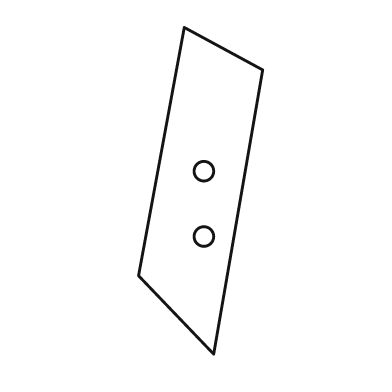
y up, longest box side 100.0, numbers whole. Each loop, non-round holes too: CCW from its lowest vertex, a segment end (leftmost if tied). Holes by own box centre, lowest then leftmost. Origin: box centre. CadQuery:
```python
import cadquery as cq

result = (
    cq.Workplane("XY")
    .moveTo(4.0, -50.0)
    .lineTo(19.0, 37.0)
    .lineTo(-5.0, 50.0)
    .lineTo(-19.0, -26.0)
    .close()
    .moveTo(1.0, -14.0)
    .circle(3.0)
    .moveTo(1.0, 6.0)
    .circle(3.0)
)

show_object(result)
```